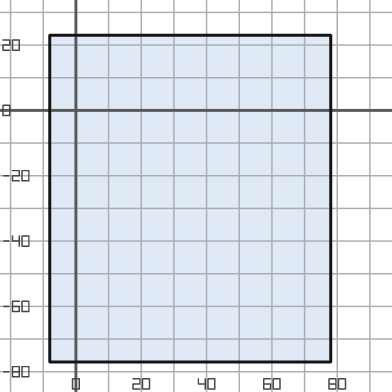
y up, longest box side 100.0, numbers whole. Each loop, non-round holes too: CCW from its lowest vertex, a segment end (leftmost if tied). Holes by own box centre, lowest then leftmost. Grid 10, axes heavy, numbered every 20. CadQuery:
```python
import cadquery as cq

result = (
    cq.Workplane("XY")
    .moveTo(-8.0, -77.0)
    .lineTo(78.0, -77.0)
    .lineTo(78.0, 23.0)
    .lineTo(-8.0, 23.0)
    .close()
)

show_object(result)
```